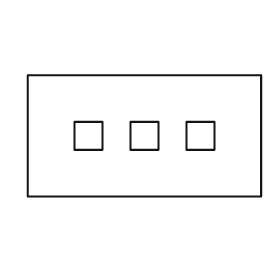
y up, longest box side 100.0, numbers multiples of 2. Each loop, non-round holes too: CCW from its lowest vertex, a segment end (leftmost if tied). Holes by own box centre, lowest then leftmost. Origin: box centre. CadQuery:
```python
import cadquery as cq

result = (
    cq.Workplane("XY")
    .moveTo(-50.0, -26.0)
    .lineTo(50.0, -26.0)
    .lineTo(50.0, 26.0)
    .lineTo(-50.0, 26.0)
    .close()
    .moveTo(-30.0, -6.0)
    .lineTo(-18.0, -6.0)
    .lineTo(-18.0, 6.0)
    .lineTo(-30.0, 6.0)
    .close()
    .moveTo(-6.0, -6.0)
    .lineTo(6.0, -6.0)
    .lineTo(6.0, 6.0)
    .lineTo(-6.0, 6.0)
    .close()
    .moveTo(18.0, -6.0)
    .lineTo(30.0, -6.0)
    .lineTo(30.0, 6.0)
    .lineTo(18.0, 6.0)
    .close()
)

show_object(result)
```